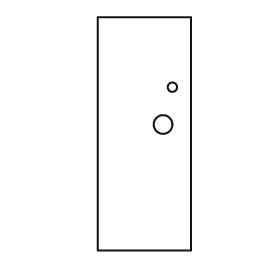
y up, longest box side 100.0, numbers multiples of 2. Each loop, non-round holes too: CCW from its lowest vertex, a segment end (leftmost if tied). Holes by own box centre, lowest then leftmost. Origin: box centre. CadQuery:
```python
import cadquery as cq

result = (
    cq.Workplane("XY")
    .moveTo(-20.0, -50.0)
    .lineTo(20.0, -50.0)
    .lineTo(20.0, 50.0)
    .lineTo(-20.0, 50.0)
    .close()
    .moveTo(8.0, 4.0)
    .circle(4.0)
    .moveTo(12.0, 20.0)
    .circle(2.0)
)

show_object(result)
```